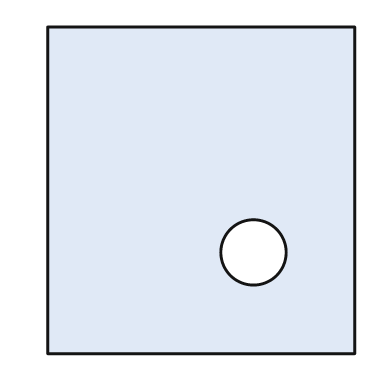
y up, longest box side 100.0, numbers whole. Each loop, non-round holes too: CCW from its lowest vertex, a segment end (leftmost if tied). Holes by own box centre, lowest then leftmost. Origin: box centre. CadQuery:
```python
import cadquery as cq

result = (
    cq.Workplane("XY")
    .moveTo(-47.0, -50.0)
    .lineTo(47.0, -50.0)
    .lineTo(47.0, 50.0)
    .lineTo(-47.0, 50.0)
    .close()
    .moveTo(16.0, -19.0)
    .circle(10.0)
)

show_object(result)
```